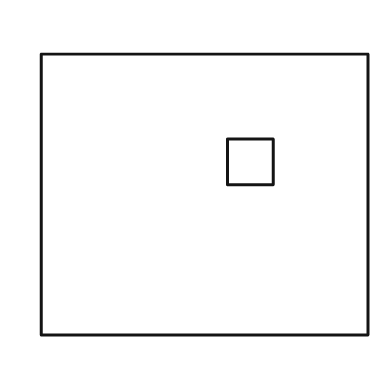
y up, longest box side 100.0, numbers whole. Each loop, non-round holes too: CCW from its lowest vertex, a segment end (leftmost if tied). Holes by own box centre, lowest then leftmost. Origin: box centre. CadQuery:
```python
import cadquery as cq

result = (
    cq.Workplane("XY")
    .moveTo(-50.0, -43.0)
    .lineTo(50.0, -43.0)
    .lineTo(50.0, 43.0)
    .lineTo(-50.0, 43.0)
    .close()
    .moveTo(7.0, 3.0)
    .lineTo(21.0, 3.0)
    .lineTo(21.0, 17.0)
    .lineTo(7.0, 17.0)
    .close()
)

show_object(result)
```